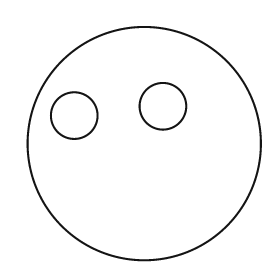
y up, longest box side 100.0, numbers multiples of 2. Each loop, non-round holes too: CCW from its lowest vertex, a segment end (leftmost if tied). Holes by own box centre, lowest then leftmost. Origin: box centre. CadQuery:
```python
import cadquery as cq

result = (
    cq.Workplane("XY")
    .moveTo(0.0, 0.0)
    .circle(50.0)
    .moveTo(-30.0, 12.0)
    .circle(10.0)
    .moveTo(8.0, 16.0)
    .circle(10.0)
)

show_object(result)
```